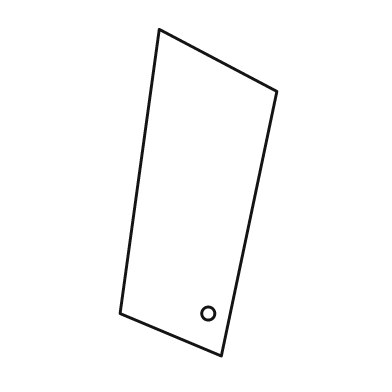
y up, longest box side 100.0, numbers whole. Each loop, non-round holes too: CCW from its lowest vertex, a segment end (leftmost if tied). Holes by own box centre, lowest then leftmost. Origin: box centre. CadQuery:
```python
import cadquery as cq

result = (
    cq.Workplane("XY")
    .moveTo(7.0, -50.0)
    .lineTo(24.0, 31.0)
    .lineTo(-12.0, 50.0)
    .lineTo(-24.0, -37.0)
    .close()
    .moveTo(3.0, -37.0)
    .circle(2.0)
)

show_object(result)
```